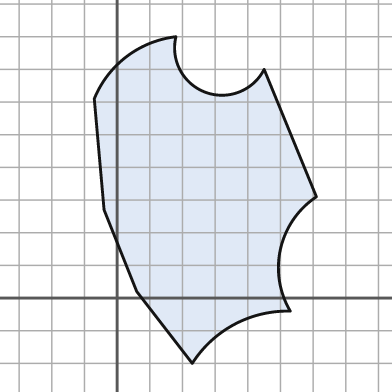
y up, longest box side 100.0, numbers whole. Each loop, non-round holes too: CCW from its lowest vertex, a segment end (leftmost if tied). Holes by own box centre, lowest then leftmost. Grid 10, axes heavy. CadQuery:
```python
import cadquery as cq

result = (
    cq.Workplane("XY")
    .moveTo(23.0, -20.0)
    .threePointArc((36.0, -8.0), (53.0, -4.0))
    .threePointArc((50.0, 15.0), (61.0, 31.0))
    .lineTo(45.0, 70.0)
    .threePointArc((27.0, 63.0), (18.0, 80.0))
    .threePointArc((3.0, 74.0), (-7.0, 61.0))
    .lineTo(-4.0, 27.0)
    .lineTo(6.0, 2.0)
    .close()
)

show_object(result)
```